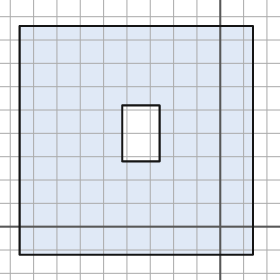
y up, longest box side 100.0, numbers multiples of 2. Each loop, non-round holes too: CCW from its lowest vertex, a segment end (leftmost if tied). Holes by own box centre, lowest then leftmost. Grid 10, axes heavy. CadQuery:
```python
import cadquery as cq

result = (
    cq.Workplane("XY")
    .moveTo(-86.0, -12.0)
    .lineTo(14.0, -12.0)
    .lineTo(14.0, 86.0)
    .lineTo(-86.0, 86.0)
    .close()
    .moveTo(-42.0, 28.0)
    .lineTo(-26.0, 28.0)
    .lineTo(-26.0, 52.0)
    .lineTo(-42.0, 52.0)
    .close()
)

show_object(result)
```